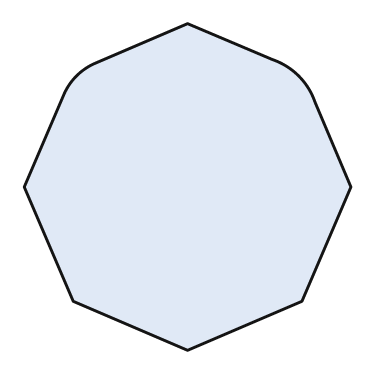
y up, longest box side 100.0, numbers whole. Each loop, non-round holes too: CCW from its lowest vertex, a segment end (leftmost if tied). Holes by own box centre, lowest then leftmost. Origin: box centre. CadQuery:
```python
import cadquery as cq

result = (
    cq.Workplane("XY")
    .moveTo(0.0, -50.0)
    .lineTo(35.0, -35.0)
    .lineTo(50.0, 0.0)
    .lineTo(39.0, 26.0)
    .threePointArc((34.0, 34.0), (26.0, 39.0))
    .lineTo(0.0, 50.0)
    .lineTo(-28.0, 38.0)
    .threePointArc((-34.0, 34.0), (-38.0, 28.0))
    .lineTo(-50.0, 0.0)
    .lineTo(-35.0, -35.0)
    .close()
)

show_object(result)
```